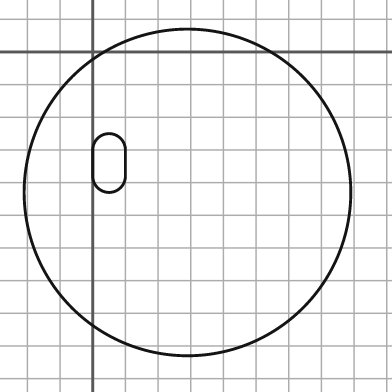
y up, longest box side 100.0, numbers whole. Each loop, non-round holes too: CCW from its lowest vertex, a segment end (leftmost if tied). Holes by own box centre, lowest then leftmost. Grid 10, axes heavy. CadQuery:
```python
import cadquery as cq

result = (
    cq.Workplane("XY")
    .moveTo(29.0, -43.0)
    .circle(50.0)
    .moveTo(0.0, -38.0)
    .threePointArc((5.0, -43.0), (10.0, -38.0))
    .lineTo(10.0, -30.0)
    .threePointArc((5.0, -25.0), (0.0, -30.0))
    .close()
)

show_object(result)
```